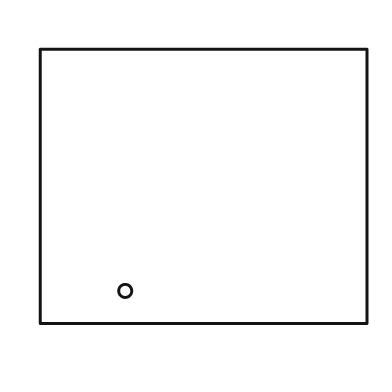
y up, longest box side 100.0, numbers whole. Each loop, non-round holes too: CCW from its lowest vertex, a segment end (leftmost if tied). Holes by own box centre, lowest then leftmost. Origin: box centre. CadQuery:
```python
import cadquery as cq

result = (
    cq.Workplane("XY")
    .moveTo(-50.0, -42.0)
    .lineTo(50.0, -42.0)
    .lineTo(50.0, 42.0)
    .lineTo(-50.0, 42.0)
    .close()
    .moveTo(-24.0, -32.0)
    .circle(2.0)
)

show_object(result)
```